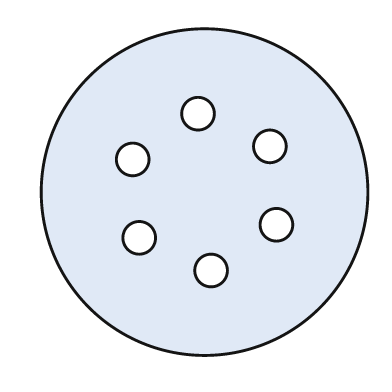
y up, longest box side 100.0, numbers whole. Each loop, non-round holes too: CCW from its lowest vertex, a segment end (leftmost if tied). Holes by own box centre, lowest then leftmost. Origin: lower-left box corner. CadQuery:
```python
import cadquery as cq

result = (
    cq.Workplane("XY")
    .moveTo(50.0, 50.0)
    .circle(50.0)
    .moveTo(52.0, 26.0)
    .circle(5.0)
    .moveTo(30.0, 36.0)
    .circle(5.0)
    .moveTo(72.0, 40.0)
    .circle(5.0)
    .moveTo(28.0, 60.0)
    .circle(5.0)
    .moveTo(70.0, 64.0)
    .circle(5.0)
    .moveTo(48.0, 74.0)
    .circle(5.0)
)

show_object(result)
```